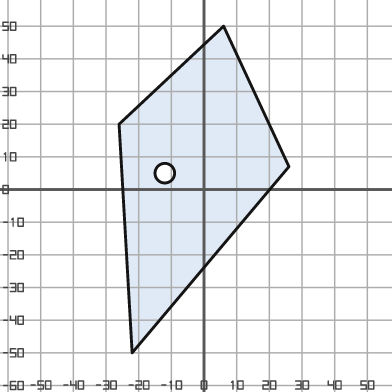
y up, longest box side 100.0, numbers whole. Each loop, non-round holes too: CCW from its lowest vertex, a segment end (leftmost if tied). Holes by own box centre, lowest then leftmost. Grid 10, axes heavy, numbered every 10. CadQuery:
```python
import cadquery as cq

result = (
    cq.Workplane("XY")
    .moveTo(-22.0, -50.0)
    .lineTo(26.0, 7.0)
    .lineTo(6.0, 50.0)
    .lineTo(-26.0, 20.0)
    .close()
    .moveTo(-12.0, 5.0)
    .circle(3.0)
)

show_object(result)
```